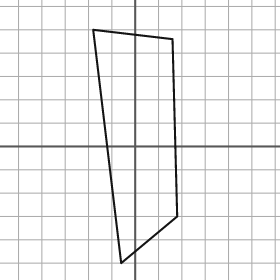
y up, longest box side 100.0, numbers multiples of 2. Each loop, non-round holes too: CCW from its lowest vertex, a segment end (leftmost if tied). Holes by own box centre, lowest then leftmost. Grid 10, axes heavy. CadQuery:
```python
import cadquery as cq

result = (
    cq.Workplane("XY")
    .moveTo(-6.0, -50.0)
    .lineTo(18.0, -30.0)
    .lineTo(16.0, 46.0)
    .lineTo(-18.0, 50.0)
    .close()
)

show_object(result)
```